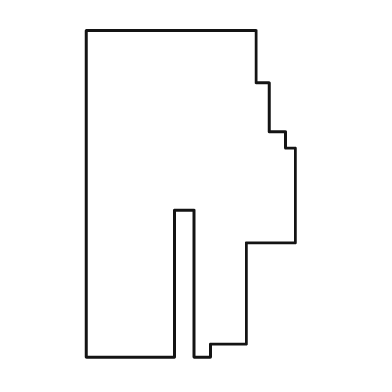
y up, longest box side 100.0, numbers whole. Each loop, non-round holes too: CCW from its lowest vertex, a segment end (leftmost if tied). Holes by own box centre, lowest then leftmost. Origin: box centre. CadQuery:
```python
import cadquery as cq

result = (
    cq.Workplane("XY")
    .moveTo(-32.0, -50.0)
    .lineTo(-5.0, -50.0)
    .lineTo(-5.0, -5.0)
    .lineTo(1.0, -5.0)
    .lineTo(1.0, -50.0)
    .lineTo(6.0, -50.0)
    .lineTo(6.0, -46.0)
    .lineTo(17.0, -46.0)
    .lineTo(17.0, -15.0)
    .lineTo(32.0, -15.0)
    .lineTo(32.0, 14.0)
    .lineTo(29.0, 14.0)
    .lineTo(29.0, 19.0)
    .lineTo(24.0, 19.0)
    .lineTo(24.0, 34.0)
    .lineTo(20.0, 34.0)
    .lineTo(20.0, 50.0)
    .lineTo(-32.0, 50.0)
    .close()
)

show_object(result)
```